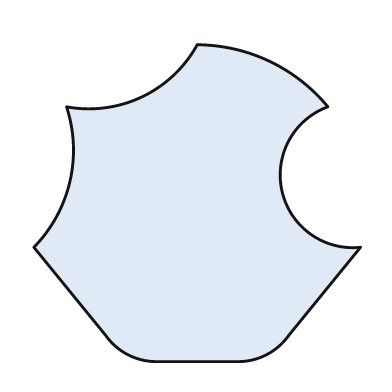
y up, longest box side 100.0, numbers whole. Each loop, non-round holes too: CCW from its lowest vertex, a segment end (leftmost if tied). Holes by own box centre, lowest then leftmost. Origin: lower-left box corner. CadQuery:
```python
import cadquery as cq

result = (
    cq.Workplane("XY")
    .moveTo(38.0, 0.0)
    .lineTo(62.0, 0.0)
    .threePointArc((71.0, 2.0), (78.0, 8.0))
    .lineTo(100.0, 35.0)
    .threePointArc((76.0, 52.0), (90.0, 78.0))
    .threePointArc((72.0, 92.0), (50.0, 97.0))
    .threePointArc((33.0, 81.0), (10.0, 78.0))
    .threePointArc((11.0, 55.0), (0.0, 35.0))
    .lineTo(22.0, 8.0)
    .threePointArc((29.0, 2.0), (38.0, 0.0))
    .close()
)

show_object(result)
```